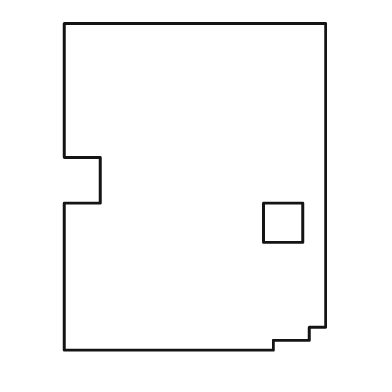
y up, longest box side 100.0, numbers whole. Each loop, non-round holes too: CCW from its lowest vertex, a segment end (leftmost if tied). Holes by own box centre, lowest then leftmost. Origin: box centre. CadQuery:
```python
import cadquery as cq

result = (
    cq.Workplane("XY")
    .moveTo(-40.0, -50.0)
    .lineTo(24.0, -50.0)
    .lineTo(24.0, -47.0)
    .lineTo(35.0, -47.0)
    .lineTo(35.0, -43.0)
    .lineTo(40.0, -43.0)
    .lineTo(40.0, 50.0)
    .lineTo(-40.0, 50.0)
    .lineTo(-40.0, 9.0)
    .lineTo(-29.0, 9.0)
    .lineTo(-29.0, -5.0)
    .lineTo(-40.0, -5.0)
    .close()
    .moveTo(21.0, -17.0)
    .lineTo(33.0, -17.0)
    .lineTo(33.0, -5.0)
    .lineTo(21.0, -5.0)
    .close()
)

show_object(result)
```